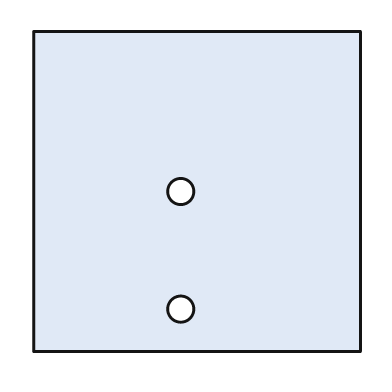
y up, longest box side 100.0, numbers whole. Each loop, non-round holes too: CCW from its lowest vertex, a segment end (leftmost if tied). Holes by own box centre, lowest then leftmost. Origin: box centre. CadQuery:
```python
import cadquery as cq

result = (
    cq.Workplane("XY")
    .moveTo(-50.0, -49.0)
    .lineTo(50.0, -49.0)
    .lineTo(50.0, 49.0)
    .lineTo(-50.0, 49.0)
    .close()
    .moveTo(-5.0, -36.0)
    .circle(4.0)
    .moveTo(-5.0, 0.0)
    .circle(4.0)
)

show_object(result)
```